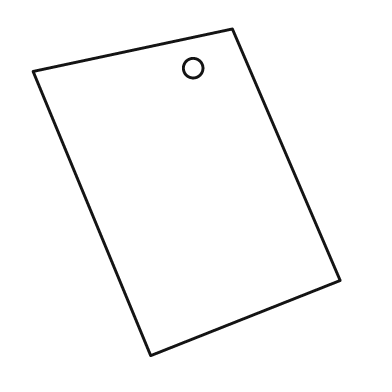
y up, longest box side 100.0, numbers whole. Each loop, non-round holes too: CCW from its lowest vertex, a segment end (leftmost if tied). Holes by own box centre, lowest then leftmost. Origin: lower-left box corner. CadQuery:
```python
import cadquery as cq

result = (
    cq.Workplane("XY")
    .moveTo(36.0, 0.0)
    .lineTo(94.0, 23.0)
    .lineTo(61.0, 100.0)
    .lineTo(0.0, 87.0)
    .close()
    .moveTo(49.0, 88.0)
    .circle(3.0)
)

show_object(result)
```